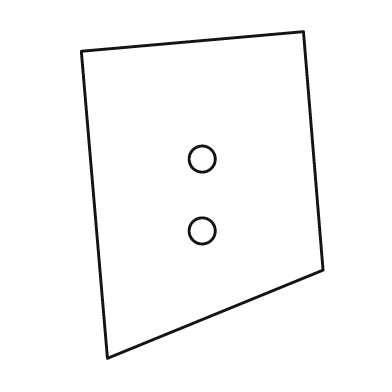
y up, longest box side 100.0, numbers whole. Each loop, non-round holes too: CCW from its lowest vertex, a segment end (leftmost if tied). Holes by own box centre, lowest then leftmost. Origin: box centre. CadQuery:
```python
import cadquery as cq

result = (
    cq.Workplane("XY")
    .moveTo(-29.0, -50.0)
    .lineTo(37.0, -23.0)
    .lineTo(31.0, 50.0)
    .lineTo(-37.0, 44.0)
    .close()
    .moveTo(0.0, -11.0)
    .circle(4.0)
    .moveTo(0.0, 11.0)
    .circle(4.0)
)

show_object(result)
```